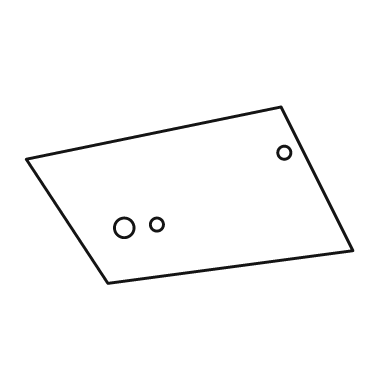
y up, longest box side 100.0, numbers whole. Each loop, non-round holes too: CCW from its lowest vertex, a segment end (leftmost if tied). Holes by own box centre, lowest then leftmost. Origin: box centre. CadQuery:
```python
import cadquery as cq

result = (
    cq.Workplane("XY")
    .moveTo(-25.0, -27.0)
    .lineTo(50.0, -17.0)
    .lineTo(28.0, 27.0)
    .lineTo(-50.0, 11.0)
    .close()
    .moveTo(-20.0, -10.0)
    .circle(3.0)
    .moveTo(-10.0, -9.0)
    .circle(2.0)
    .moveTo(29.0, 13.0)
    .circle(2.0)
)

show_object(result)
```